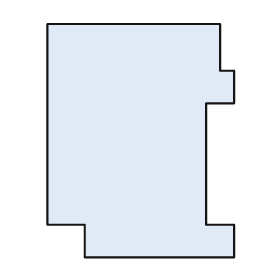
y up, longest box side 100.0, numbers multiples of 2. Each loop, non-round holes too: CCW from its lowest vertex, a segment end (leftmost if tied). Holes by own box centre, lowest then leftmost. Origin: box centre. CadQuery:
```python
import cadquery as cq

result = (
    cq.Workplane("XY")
    .moveTo(-24.0, -50.0)
    .lineTo(40.0, -50.0)
    .lineTo(40.0, -36.0)
    .lineTo(28.0, -36.0)
    .lineTo(28.0, 16.0)
    .lineTo(40.0, 16.0)
    .lineTo(40.0, 30.0)
    .lineTo(34.0, 30.0)
    .lineTo(34.0, 50.0)
    .lineTo(-40.0, 50.0)
    .lineTo(-40.0, -36.0)
    .lineTo(-24.0, -36.0)
    .close()
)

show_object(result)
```